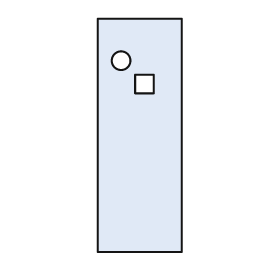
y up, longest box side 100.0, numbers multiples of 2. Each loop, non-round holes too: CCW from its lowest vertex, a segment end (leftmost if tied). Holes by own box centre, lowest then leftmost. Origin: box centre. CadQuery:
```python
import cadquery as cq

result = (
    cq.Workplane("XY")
    .moveTo(-18.0, -50.0)
    .lineTo(18.0, -50.0)
    .lineTo(18.0, 50.0)
    .lineTo(-18.0, 50.0)
    .close()
    .moveTo(-2.0, 18.0)
    .lineTo(6.0, 18.0)
    .lineTo(6.0, 26.0)
    .lineTo(-2.0, 26.0)
    .close()
    .moveTo(-8.0, 32.0)
    .circle(4.0)
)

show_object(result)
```